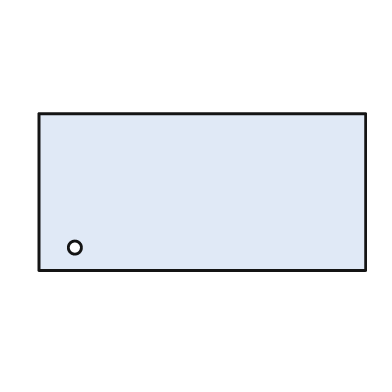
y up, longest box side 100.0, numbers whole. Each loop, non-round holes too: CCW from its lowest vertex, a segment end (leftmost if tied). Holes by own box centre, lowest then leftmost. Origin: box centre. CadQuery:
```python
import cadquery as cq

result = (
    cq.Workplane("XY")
    .moveTo(-50.0, -24.0)
    .lineTo(50.0, -24.0)
    .lineTo(50.0, 24.0)
    .lineTo(-50.0, 24.0)
    .close()
    .moveTo(-39.0, -17.0)
    .circle(2.0)
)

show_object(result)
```